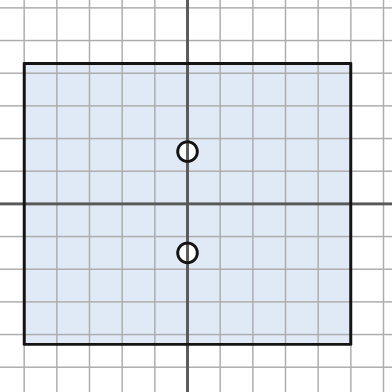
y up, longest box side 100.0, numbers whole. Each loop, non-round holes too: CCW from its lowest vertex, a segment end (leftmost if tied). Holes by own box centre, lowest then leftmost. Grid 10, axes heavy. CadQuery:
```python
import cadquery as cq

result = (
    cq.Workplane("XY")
    .moveTo(-50.0, -43.0)
    .lineTo(50.0, -43.0)
    .lineTo(50.0, 43.0)
    .lineTo(-50.0, 43.0)
    .close()
    .moveTo(0.0, -15.0)
    .circle(3.0)
    .moveTo(0.0, 16.0)
    .circle(3.0)
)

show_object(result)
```